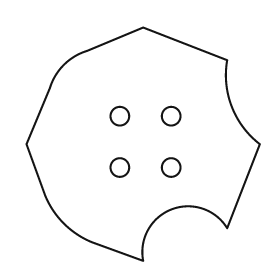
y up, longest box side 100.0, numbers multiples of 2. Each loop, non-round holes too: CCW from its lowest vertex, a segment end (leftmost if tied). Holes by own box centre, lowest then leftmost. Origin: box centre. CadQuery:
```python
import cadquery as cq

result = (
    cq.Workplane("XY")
    .moveTo(0.0, -50.0)
    .threePointArc((12.0, -28.0), (36.0, -36.0))
    .lineTo(50.0, 0.0)
    .threePointArc((38.0, 16.0), (36.0, 36.0))
    .lineTo(0.0, 50.0)
    .lineTo(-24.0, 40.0)
    .threePointArc((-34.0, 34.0), (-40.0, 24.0))
    .lineTo(-50.0, 0.0)
    .lineTo(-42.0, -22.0)
    .threePointArc((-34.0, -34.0), (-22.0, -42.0))
    .close()
    .moveTo(-10.0, -10.0)
    .circle(4.0)
    .moveTo(12.0, -10.0)
    .circle(4.0)
    .moveTo(-10.0, 12.0)
    .circle(4.0)
    .moveTo(12.0, 12.0)
    .circle(4.0)
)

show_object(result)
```